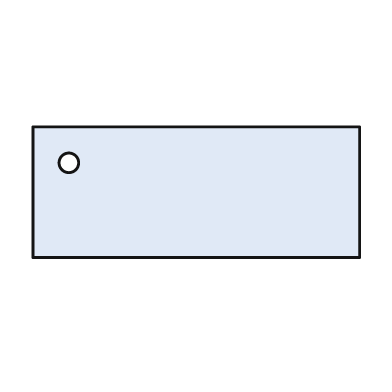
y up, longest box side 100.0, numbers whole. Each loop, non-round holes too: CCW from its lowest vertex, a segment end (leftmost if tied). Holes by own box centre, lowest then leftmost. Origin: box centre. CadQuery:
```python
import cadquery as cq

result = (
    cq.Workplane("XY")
    .moveTo(-50.0, -20.0)
    .lineTo(50.0, -20.0)
    .lineTo(50.0, 20.0)
    .lineTo(-50.0, 20.0)
    .close()
    .moveTo(-39.0, 9.0)
    .circle(3.0)
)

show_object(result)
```